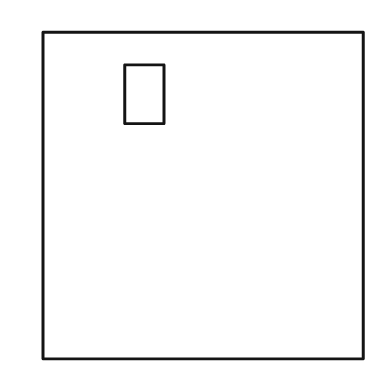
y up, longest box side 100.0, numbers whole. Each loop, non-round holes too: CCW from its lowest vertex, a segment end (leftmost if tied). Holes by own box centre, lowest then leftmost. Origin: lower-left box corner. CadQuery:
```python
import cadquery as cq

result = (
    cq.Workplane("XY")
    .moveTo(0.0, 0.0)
    .lineTo(98.0, 0.0)
    .lineTo(98.0, 100.0)
    .lineTo(0.0, 100.0)
    .close()
    .moveTo(25.0, 72.0)
    .lineTo(37.0, 72.0)
    .lineTo(37.0, 90.0)
    .lineTo(25.0, 90.0)
    .close()
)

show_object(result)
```